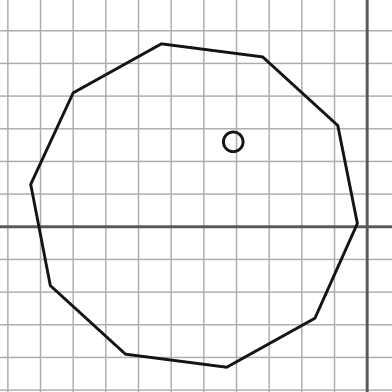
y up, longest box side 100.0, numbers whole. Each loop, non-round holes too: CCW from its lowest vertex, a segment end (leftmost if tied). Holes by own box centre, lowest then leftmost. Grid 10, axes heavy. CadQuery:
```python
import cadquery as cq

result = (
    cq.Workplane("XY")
    .moveTo(-43.0, -43.0)
    .lineTo(-16.0, -28.0)
    .lineTo(-3.0, 1.0)
    .lineTo(-9.0, 31.0)
    .lineTo(-32.0, 52.0)
    .lineTo(-63.0, 56.0)
    .lineTo(-90.0, 41.0)
    .lineTo(-103.0, 13.0)
    .lineTo(-97.0, -18.0)
    .lineTo(-74.0, -39.0)
    .close()
    .moveTo(-41.0, 26.0)
    .circle(3.0)
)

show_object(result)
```